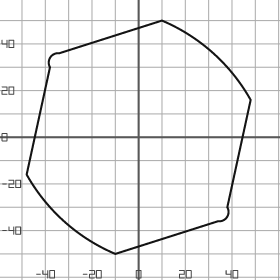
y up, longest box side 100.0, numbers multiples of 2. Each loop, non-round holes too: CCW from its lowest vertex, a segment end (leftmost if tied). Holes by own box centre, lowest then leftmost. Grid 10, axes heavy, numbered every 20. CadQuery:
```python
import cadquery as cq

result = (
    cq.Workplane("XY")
    .moveTo(-10.0, -50.0)
    .lineTo(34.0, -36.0)
    .threePointArc((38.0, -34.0), (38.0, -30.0))
    .lineTo(48.0, 16.0)
    .threePointArc((32.0, 36.0), (10.0, 50.0))
    .lineTo(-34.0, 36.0)
    .threePointArc((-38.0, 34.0), (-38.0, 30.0))
    .lineTo(-48.0, -16.0)
    .threePointArc((-32.0, -36.0), (-10.0, -50.0))
    .close()
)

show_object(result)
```